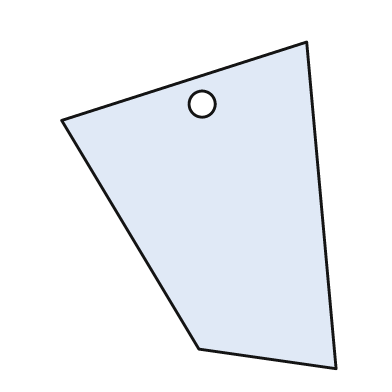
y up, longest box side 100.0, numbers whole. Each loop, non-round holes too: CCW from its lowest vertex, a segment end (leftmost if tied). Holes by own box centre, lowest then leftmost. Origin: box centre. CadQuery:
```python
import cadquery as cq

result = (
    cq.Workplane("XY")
    .moveTo(42.0, -50.0)
    .lineTo(33.0, 50.0)
    .lineTo(-42.0, 26.0)
    .lineTo(0.0, -44.0)
    .close()
    .moveTo(1.0, 31.0)
    .circle(4.0)
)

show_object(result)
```